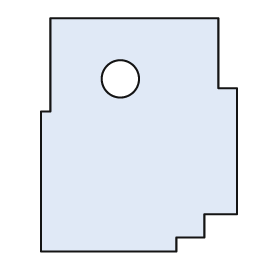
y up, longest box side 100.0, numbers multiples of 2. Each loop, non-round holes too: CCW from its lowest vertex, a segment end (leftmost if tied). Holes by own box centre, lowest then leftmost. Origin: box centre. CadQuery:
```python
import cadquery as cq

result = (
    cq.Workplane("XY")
    .moveTo(-42.0, -50.0)
    .lineTo(16.0, -50.0)
    .lineTo(16.0, -44.0)
    .lineTo(28.0, -44.0)
    .lineTo(28.0, -34.0)
    .lineTo(42.0, -34.0)
    .lineTo(42.0, 20.0)
    .lineTo(34.0, 20.0)
    .lineTo(34.0, 50.0)
    .lineTo(-38.0, 50.0)
    .lineTo(-38.0, 10.0)
    .lineTo(-42.0, 10.0)
    .close()
    .moveTo(-8.0, 24.0)
    .circle(8.0)
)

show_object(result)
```